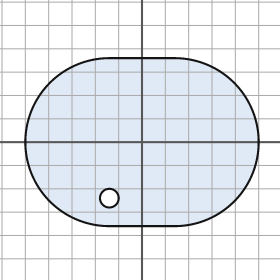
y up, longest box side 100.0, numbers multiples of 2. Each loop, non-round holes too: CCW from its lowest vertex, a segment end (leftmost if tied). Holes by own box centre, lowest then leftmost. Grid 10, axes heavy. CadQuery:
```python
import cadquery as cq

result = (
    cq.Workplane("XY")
    .moveTo(-14.0, -36.0)
    .lineTo(14.0, -36.0)
    .threePointArc((50.0, 0.0), (14.0, 36.0))
    .lineTo(-14.0, 36.0)
    .threePointArc((-50.0, 0.0), (-14.0, -36.0))
    .close()
    .moveTo(-14.0, -24.0)
    .circle(4.0)
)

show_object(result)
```